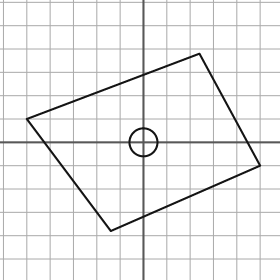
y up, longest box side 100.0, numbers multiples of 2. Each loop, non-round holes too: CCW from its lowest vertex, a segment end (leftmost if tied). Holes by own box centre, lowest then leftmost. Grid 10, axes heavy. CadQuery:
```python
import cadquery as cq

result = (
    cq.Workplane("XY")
    .moveTo(-14.0, -38.0)
    .lineTo(50.0, -10.0)
    .lineTo(24.0, 38.0)
    .lineTo(-50.0, 10.0)
    .close()
    .moveTo(0.0, 0.0)
    .circle(6.0)
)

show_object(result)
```